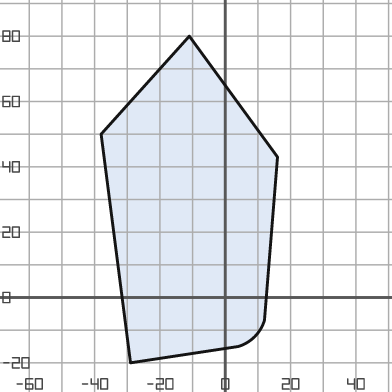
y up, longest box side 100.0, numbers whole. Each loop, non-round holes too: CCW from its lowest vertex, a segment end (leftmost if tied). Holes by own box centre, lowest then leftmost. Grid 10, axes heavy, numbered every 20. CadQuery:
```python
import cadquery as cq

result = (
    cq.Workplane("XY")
    .moveTo(-29.0, -20.0)
    .lineTo(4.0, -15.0)
    .threePointArc((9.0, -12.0), (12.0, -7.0))
    .lineTo(16.0, 43.0)
    .lineTo(-11.0, 80.0)
    .lineTo(-38.0, 50.0)
    .close()
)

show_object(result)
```